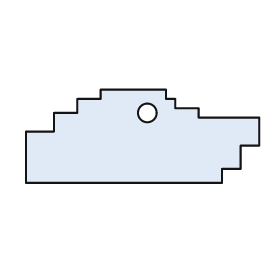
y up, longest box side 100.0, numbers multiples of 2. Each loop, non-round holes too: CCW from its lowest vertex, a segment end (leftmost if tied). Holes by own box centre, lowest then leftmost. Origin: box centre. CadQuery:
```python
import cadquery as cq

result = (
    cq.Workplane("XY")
    .moveTo(-50.0, -20.0)
    .lineTo(34.0, -20.0)
    .lineTo(34.0, -14.0)
    .lineTo(42.0, -14.0)
    .lineTo(42.0, -4.0)
    .lineTo(50.0, -4.0)
    .lineTo(50.0, 8.0)
    .lineTo(24.0, 8.0)
    .lineTo(24.0, 12.0)
    .lineTo(14.0, 12.0)
    .lineTo(14.0, 16.0)
    .lineTo(10.0, 16.0)
    .lineTo(10.0, 20.0)
    .lineTo(-18.0, 20.0)
    .lineTo(-18.0, 16.0)
    .lineTo(-28.0, 16.0)
    .lineTo(-28.0, 10.0)
    .lineTo(-38.0, 10.0)
    .lineTo(-38.0, 2.0)
    .lineTo(-50.0, 2.0)
    .close()
    .moveTo(2.0, 10.0)
    .circle(4.0)
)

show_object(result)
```